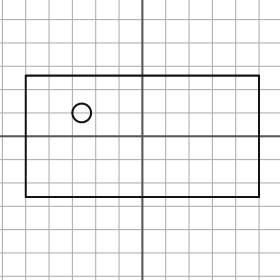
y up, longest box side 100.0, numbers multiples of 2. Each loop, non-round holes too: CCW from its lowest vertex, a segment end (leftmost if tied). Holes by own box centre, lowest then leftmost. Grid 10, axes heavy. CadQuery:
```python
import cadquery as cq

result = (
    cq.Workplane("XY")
    .moveTo(-50.0, -26.0)
    .lineTo(50.0, -26.0)
    .lineTo(50.0, 26.0)
    .lineTo(-50.0, 26.0)
    .close()
    .moveTo(-26.0, 10.0)
    .circle(4.0)
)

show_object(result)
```